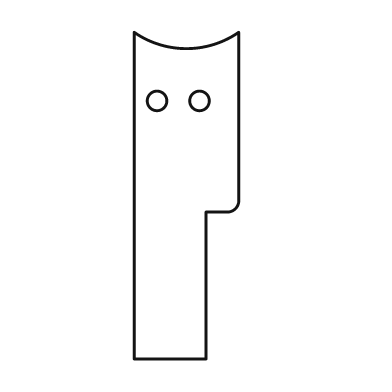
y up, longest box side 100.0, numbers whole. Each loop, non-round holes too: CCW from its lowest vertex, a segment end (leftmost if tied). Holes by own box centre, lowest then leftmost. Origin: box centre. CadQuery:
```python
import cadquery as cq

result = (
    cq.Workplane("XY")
    .moveTo(-16.0, -50.0)
    .lineTo(6.0, -50.0)
    .lineTo(6.0, -5.0)
    .lineTo(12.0, -5.0)
    .threePointArc((15.0, -4.0), (16.0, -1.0))
    .lineTo(16.0, 50.0)
    .threePointArc((0.0, 45.0), (-16.0, 50.0))
    .close()
    .moveTo(-9.0, 29.0)
    .circle(3.0)
    .moveTo(4.0, 29.0)
    .circle(3.0)
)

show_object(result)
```